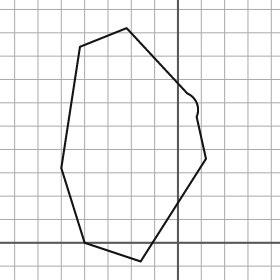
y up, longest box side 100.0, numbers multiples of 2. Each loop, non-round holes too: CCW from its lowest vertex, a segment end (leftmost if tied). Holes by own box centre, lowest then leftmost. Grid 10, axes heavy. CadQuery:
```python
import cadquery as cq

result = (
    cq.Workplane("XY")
    .moveTo(-16.0, -8.0)
    .lineTo(12.0, 36.0)
    .lineTo(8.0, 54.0)
    .threePointArc((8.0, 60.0), (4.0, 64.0))
    .lineTo(-22.0, 92.0)
    .lineTo(-42.0, 84.0)
    .lineTo(-50.0, 32.0)
    .lineTo(-40.0, 0.0)
    .close()
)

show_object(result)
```